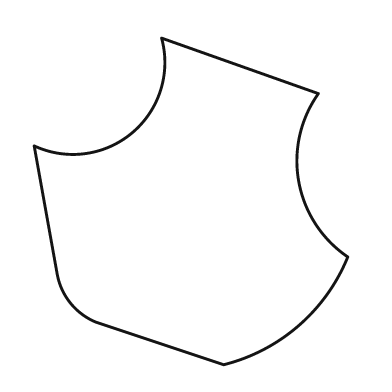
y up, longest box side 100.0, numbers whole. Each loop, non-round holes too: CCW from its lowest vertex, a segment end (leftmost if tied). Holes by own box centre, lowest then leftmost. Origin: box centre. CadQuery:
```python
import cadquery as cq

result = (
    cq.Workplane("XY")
    .moveTo(10.0, -50.0)
    .threePointArc((33.0, -38.0), (48.0, -17.0))
    .threePointArc((33.0, 6.0), (39.0, 33.0))
    .lineTo(-9.0, 50.0)
    .threePointArc((-18.0, 21.0), (-48.0, 17.0))
    .lineTo(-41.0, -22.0)
    .threePointArc((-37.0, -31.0), (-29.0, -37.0))
    .close()
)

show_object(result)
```